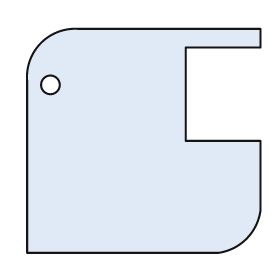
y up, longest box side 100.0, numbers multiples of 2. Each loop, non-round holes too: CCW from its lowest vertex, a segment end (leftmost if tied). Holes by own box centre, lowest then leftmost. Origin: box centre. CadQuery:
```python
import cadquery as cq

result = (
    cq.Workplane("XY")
    .moveTo(-50.0, -48.0)
    .lineTo(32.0, -48.0)
    .threePointArc((44.0, -42.0), (50.0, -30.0))
    .lineTo(50.0, 0.0)
    .lineTo(18.0, 0.0)
    .lineTo(18.0, 40.0)
    .lineTo(50.0, 40.0)
    .lineTo(50.0, 48.0)
    .lineTo(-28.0, 48.0)
    .threePointArc((-44.0, 42.0), (-50.0, 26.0))
    .close()
    .moveTo(-40.0, 24.0)
    .circle(4.0)
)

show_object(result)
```